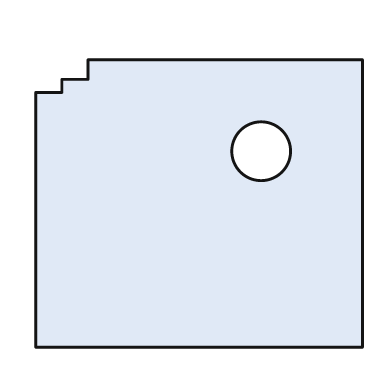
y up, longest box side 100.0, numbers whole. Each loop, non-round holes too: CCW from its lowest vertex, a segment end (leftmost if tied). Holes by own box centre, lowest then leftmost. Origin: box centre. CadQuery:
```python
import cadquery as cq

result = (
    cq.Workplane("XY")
    .moveTo(-50.0, -44.0)
    .lineTo(50.0, -44.0)
    .lineTo(50.0, 44.0)
    .lineTo(-34.0, 44.0)
    .lineTo(-34.0, 38.0)
    .lineTo(-42.0, 38.0)
    .lineTo(-42.0, 34.0)
    .lineTo(-50.0, 34.0)
    .close()
    .moveTo(19.0, 16.0)
    .circle(9.0)
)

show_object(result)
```